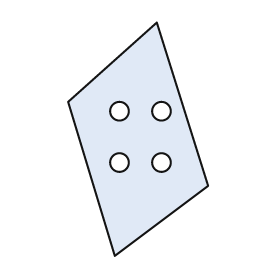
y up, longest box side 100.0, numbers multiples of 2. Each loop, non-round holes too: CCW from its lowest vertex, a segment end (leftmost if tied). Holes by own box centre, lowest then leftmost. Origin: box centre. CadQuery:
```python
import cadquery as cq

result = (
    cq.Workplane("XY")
    .moveTo(-10.0, -50.0)
    .lineTo(30.0, -20.0)
    .lineTo(8.0, 50.0)
    .lineTo(-30.0, 16.0)
    .close()
    .moveTo(-8.0, -10.0)
    .circle(4.0)
    .moveTo(10.0, -10.0)
    .circle(4.0)
    .moveTo(-8.0, 12.0)
    .circle(4.0)
    .moveTo(10.0, 12.0)
    .circle(4.0)
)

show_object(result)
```